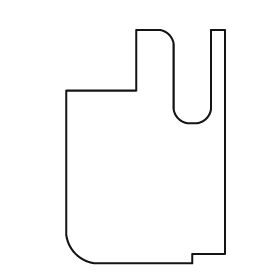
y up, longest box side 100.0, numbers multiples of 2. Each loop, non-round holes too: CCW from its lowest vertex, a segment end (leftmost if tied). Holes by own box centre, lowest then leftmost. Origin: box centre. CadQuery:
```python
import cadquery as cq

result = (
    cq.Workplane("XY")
    .moveTo(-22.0, -50.0)
    .lineTo(20.0, -50.0)
    .lineTo(20.0, -46.0)
    .lineTo(34.0, -46.0)
    .lineTo(34.0, 50.0)
    .lineTo(28.0, 50.0)
    .lineTo(28.0, 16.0)
    .threePointArc((26.0, 12.0), (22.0, 10.0))
    .lineTo(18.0, 10.0)
    .threePointArc((14.0, 12.0), (12.0, 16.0))
    .lineTo(12.0, 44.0)
    .threePointArc((10.0, 48.0), (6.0, 50.0))
    .lineTo(-4.0, 50.0)
    .lineTo(-4.0, 24.0)
    .lineTo(-34.0, 24.0)
    .lineTo(-34.0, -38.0)
    .threePointArc((-30.0, -46.0), (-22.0, -50.0))
    .close()
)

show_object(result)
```